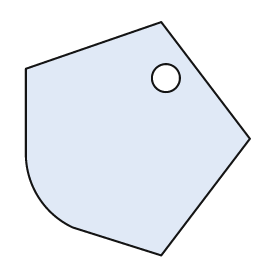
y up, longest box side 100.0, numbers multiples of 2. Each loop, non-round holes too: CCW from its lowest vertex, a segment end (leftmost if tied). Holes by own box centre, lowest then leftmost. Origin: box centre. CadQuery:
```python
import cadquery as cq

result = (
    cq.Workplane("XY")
    .moveTo(10.0, -50.0)
    .lineTo(48.0, 0.0)
    .lineTo(10.0, 50.0)
    .lineTo(-48.0, 30.0)
    .lineTo(-48.0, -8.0)
    .threePointArc((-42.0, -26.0), (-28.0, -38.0))
    .close()
    .moveTo(12.0, 26.0)
    .circle(6.0)
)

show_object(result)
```